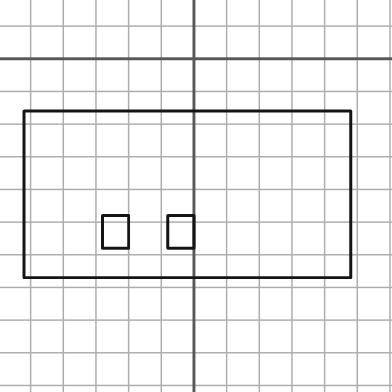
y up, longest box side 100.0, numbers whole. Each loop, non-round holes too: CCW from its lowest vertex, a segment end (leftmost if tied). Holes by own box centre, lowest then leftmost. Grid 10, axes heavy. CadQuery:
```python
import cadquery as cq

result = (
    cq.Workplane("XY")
    .moveTo(-52.0, -67.0)
    .lineTo(48.0, -67.0)
    .lineTo(48.0, -16.0)
    .lineTo(-52.0, -16.0)
    .close()
    .moveTo(-28.0, -58.0)
    .lineTo(-20.0, -58.0)
    .lineTo(-20.0, -48.0)
    .lineTo(-28.0, -48.0)
    .close()
    .moveTo(-8.0, -58.0)
    .lineTo(0.0, -58.0)
    .lineTo(0.0, -48.0)
    .lineTo(-8.0, -48.0)
    .close()
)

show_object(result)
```